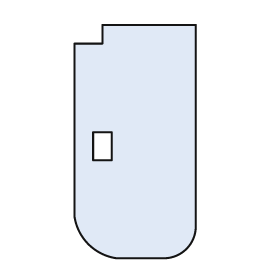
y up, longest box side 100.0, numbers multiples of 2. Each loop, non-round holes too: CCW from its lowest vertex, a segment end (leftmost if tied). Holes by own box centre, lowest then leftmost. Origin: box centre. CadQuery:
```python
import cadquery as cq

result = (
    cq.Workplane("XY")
    .moveTo(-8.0, -50.0)
    .lineTo(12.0, -50.0)
    .threePointArc((22.0, -46.0), (26.0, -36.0))
    .lineTo(26.0, 50.0)
    .lineTo(-14.0, 50.0)
    .lineTo(-14.0, 42.0)
    .lineTo(-26.0, 42.0)
    .lineTo(-26.0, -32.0)
    .threePointArc((-20.0, -44.0), (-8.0, -50.0))
    .close()
    .moveTo(-18.0, -8.0)
    .lineTo(-10.0, -8.0)
    .lineTo(-10.0, 4.0)
    .lineTo(-18.0, 4.0)
    .close()
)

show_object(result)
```